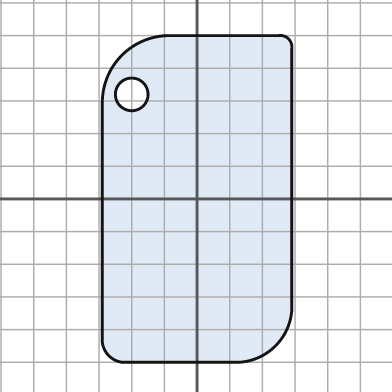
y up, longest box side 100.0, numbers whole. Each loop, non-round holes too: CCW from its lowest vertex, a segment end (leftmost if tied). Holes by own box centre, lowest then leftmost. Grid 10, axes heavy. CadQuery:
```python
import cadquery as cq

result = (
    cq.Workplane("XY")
    .moveTo(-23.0, -50.0)
    .lineTo(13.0, -50.0)
    .threePointArc((24.0, -45.0), (29.0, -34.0))
    .lineTo(29.0, 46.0)
    .threePointArc((28.0, 49.0), (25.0, 50.0))
    .lineTo(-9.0, 50.0)
    .threePointArc((-23.0, 44.0), (-29.0, 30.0))
    .lineTo(-29.0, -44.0)
    .threePointArc((-27.0, -48.0), (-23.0, -50.0))
    .close()
    .moveTo(-20.0, 32.0)
    .circle(5.0)
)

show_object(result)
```